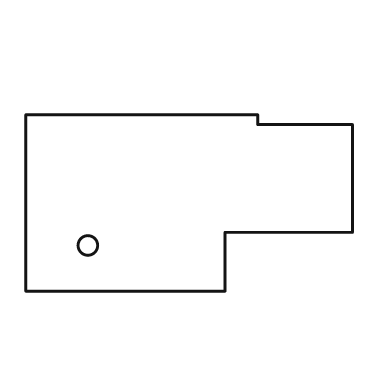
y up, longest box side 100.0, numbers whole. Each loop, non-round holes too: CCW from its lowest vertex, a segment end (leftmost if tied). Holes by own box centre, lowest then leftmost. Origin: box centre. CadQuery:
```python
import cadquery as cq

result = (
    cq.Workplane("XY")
    .moveTo(-50.0, -27.0)
    .lineTo(11.0, -27.0)
    .lineTo(11.0, -9.0)
    .lineTo(50.0, -9.0)
    .lineTo(50.0, 24.0)
    .lineTo(21.0, 24.0)
    .lineTo(21.0, 27.0)
    .lineTo(-50.0, 27.0)
    .close()
    .moveTo(-31.0, -13.0)
    .circle(3.0)
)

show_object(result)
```